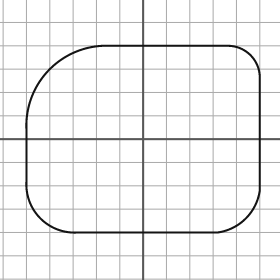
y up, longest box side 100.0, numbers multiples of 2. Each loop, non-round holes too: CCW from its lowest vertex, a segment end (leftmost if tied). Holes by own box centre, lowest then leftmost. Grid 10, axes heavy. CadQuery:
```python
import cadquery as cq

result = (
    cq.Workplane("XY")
    .moveTo(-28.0, -40.0)
    .lineTo(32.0, -40.0)
    .threePointArc((44.0, -34.0), (50.0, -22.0))
    .lineTo(50.0, 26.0)
    .threePointArc((46.0, 36.0), (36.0, 40.0))
    .lineTo(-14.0, 40.0)
    .threePointArc((-40.0, 30.0), (-50.0, 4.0))
    .lineTo(-50.0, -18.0)
    .threePointArc((-44.0, -34.0), (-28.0, -40.0))
    .close()
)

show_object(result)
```